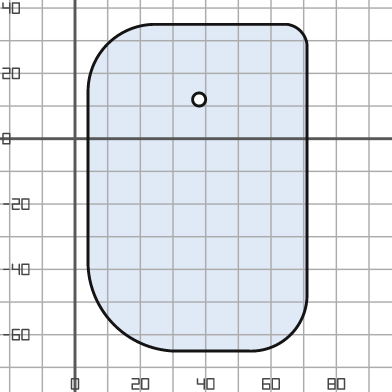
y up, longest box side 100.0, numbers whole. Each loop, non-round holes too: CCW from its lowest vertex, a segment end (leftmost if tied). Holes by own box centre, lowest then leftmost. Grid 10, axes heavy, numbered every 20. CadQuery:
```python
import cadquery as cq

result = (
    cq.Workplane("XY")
    .moveTo(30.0, -65.0)
    .lineTo(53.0, -65.0)
    .threePointArc((66.0, -60.0), (71.0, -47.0))
    .lineTo(71.0, 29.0)
    .threePointArc((69.0, 33.0), (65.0, 35.0))
    .lineTo(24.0, 35.0)
    .threePointArc((10.0, 29.0), (4.0, 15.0))
    .lineTo(4.0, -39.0)
    .threePointArc((12.0, -57.0), (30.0, -65.0))
    .close()
    .moveTo(38.0, 12.0)
    .circle(2.0)
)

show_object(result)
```